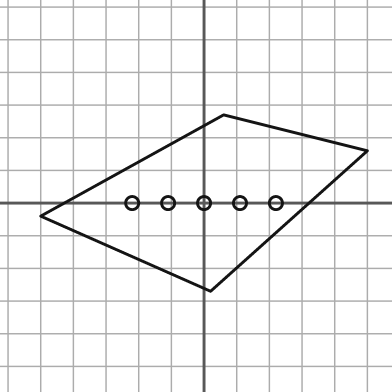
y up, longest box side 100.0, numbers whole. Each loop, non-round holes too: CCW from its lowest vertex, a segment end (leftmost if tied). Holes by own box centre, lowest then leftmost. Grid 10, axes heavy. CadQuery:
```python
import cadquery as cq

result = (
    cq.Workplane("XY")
    .moveTo(2.0, -27.0)
    .lineTo(50.0, 16.0)
    .lineTo(6.0, 27.0)
    .lineTo(-50.0, -4.0)
    .close()
    .moveTo(-22.0, 0.0)
    .circle(2.0)
    .moveTo(-11.0, 0.0)
    .circle(2.0)
    .moveTo(0.0, 0.0)
    .circle(2.0)
    .moveTo(11.0, 0.0)
    .circle(2.0)
    .moveTo(22.0, 0.0)
    .circle(2.0)
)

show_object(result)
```